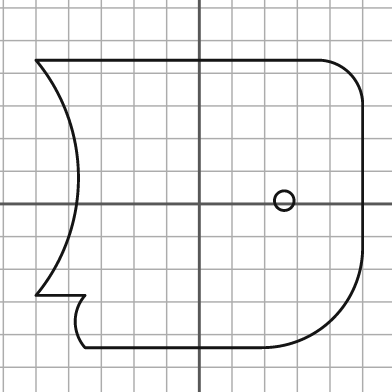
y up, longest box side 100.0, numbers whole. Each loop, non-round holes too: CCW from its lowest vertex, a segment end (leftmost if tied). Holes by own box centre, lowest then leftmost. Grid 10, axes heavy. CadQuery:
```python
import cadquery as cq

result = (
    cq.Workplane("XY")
    .moveTo(-35.0, -44.0)
    .lineTo(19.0, -44.0)
    .threePointArc((41.0, -35.0), (50.0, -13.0))
    .lineTo(50.0, 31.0)
    .threePointArc((46.0, 40.0), (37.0, 44.0))
    .lineTo(-50.0, 44.0)
    .threePointArc((-37.0, 8.0), (-50.0, -28.0))
    .lineTo(-35.0, -28.0)
    .threePointArc((-38.0, -36.0), (-35.0, -44.0))
    .close()
    .moveTo(26.0, 1.0)
    .circle(3.0)
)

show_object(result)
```